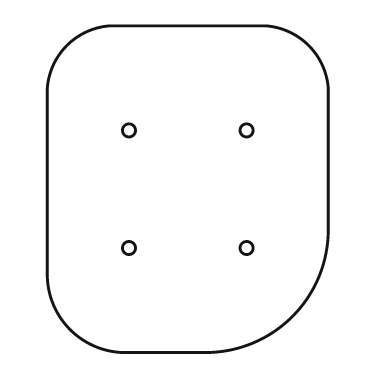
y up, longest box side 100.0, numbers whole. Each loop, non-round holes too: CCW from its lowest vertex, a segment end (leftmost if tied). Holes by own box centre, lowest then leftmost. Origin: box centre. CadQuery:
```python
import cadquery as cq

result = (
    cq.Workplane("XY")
    .moveTo(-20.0, -50.0)
    .lineTo(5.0, -50.0)
    .threePointArc((32.0, -39.0), (43.0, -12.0))
    .lineTo(43.0, 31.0)
    .threePointArc((37.0, 44.0), (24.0, 50.0))
    .lineTo(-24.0, 50.0)
    .threePointArc((-37.0, 44.0), (-43.0, 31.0))
    .lineTo(-43.0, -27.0)
    .threePointArc((-36.0, -43.0), (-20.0, -50.0))
    .close()
    .moveTo(-18.0, -18.0)
    .circle(2.0)
    .moveTo(18.0, -18.0)
    .circle(2.0)
    .moveTo(-18.0, 18.0)
    .circle(2.0)
    .moveTo(18.0, 18.0)
    .circle(2.0)
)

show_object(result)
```